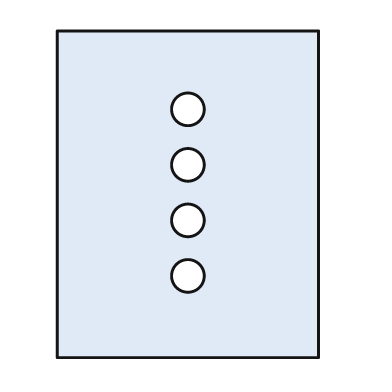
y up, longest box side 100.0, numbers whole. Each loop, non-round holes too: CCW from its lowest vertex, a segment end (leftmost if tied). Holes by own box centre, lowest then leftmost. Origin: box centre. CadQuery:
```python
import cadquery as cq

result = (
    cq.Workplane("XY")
    .moveTo(-40.0, -50.0)
    .lineTo(40.0, -50.0)
    .lineTo(40.0, 50.0)
    .lineTo(-40.0, 50.0)
    .close()
    .moveTo(0.0, -25.0)
    .circle(5.0)
    .moveTo(0.0, -8.0)
    .circle(5.0)
    .moveTo(0.0, 9.0)
    .circle(5.0)
    .moveTo(0.0, 26.0)
    .circle(5.0)
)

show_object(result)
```